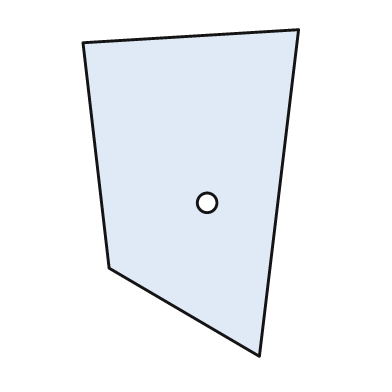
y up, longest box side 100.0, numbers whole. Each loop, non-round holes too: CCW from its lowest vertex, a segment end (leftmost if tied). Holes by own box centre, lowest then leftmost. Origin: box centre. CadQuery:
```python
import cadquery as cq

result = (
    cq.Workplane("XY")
    .moveTo(21.0, -50.0)
    .lineTo(33.0, 50.0)
    .lineTo(-33.0, 46.0)
    .lineTo(-25.0, -23.0)
    .close()
    .moveTo(5.0, -3.0)
    .circle(3.0)
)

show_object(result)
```